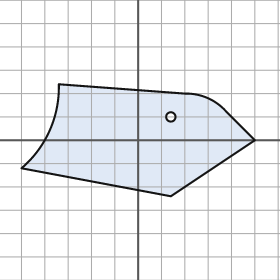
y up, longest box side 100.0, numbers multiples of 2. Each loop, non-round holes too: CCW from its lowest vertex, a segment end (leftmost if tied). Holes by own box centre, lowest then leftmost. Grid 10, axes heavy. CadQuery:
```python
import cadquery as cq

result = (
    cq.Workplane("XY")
    .moveTo(14.0, -24.0)
    .lineTo(50.0, 0.0)
    .lineTo(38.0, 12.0)
    .threePointArc((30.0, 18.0), (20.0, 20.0))
    .lineTo(-34.0, 24.0)
    .threePointArc((-38.0, 4.0), (-50.0, -12.0))
    .close()
    .moveTo(14.0, 10.0)
    .circle(2.0)
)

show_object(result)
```